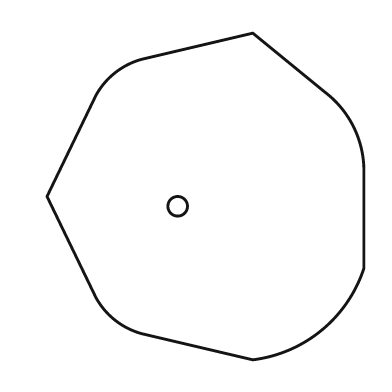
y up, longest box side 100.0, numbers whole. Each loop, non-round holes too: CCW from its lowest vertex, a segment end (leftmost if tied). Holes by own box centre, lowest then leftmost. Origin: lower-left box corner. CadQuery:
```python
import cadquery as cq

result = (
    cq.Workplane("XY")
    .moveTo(63.0, 0.0)
    .threePointArc((84.0, 9.0), (97.0, 28.0))
    .lineTo(97.0, 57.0)
    .threePointArc((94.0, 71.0), (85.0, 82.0))
    .lineTo(63.0, 100.0)
    .lineTo(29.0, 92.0)
    .threePointArc((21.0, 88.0), (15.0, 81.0))
    .lineTo(0.0, 50.0)
    .lineTo(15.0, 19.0)
    .threePointArc((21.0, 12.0), (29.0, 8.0))
    .close()
    .moveTo(40.0, 47.0)
    .circle(3.0)
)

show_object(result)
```